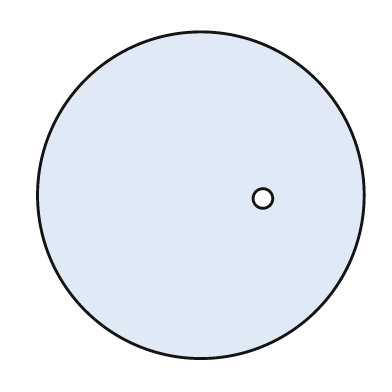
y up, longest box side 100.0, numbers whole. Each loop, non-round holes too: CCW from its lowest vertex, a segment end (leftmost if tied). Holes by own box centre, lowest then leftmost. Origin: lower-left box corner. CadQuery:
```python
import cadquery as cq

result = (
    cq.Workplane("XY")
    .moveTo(50.0, 50.0)
    .circle(50.0)
    .moveTo(69.0, 49.0)
    .circle(3.0)
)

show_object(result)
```